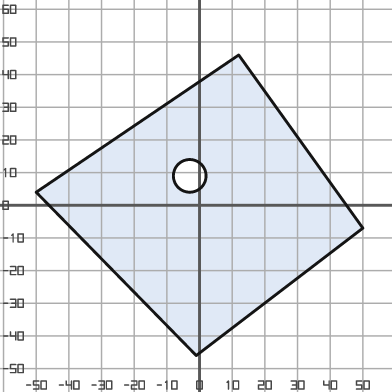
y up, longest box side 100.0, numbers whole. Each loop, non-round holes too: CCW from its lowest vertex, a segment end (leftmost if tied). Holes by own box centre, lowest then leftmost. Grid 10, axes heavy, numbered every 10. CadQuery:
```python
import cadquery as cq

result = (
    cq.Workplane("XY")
    .moveTo(-1.0, -46.0)
    .lineTo(50.0, -7.0)
    .lineTo(12.0, 46.0)
    .lineTo(-50.0, 4.0)
    .close()
    .moveTo(-3.0, 9.0)
    .circle(5.0)
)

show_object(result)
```